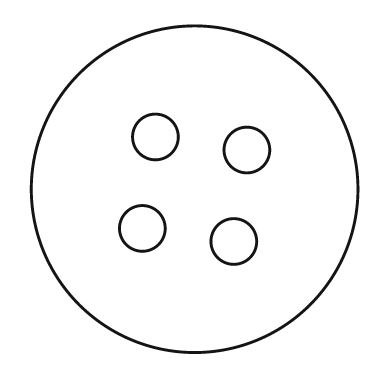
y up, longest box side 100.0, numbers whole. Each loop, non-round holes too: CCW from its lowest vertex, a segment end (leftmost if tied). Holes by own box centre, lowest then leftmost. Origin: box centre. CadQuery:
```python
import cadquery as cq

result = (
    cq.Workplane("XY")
    .moveTo(0.0, 0.0)
    .circle(50.0)
    .moveTo(12.0, -16.0)
    .circle(7.0)
    .moveTo(-16.0, -12.0)
    .circle(7.0)
    .moveTo(16.0, 12.0)
    .circle(7.0)
    .moveTo(-12.0, 16.0)
    .circle(7.0)
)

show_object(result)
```